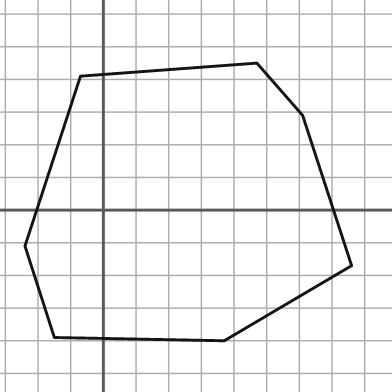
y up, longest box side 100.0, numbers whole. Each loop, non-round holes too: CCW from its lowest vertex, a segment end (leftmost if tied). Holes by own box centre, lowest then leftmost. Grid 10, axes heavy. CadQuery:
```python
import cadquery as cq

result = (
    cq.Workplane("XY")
    .moveTo(37.0, -40.0)
    .lineTo(76.0, -17.0)
    .lineTo(61.0, 29.0)
    .lineTo(47.0, 45.0)
    .lineTo(-7.0, 41.0)
    .lineTo(-24.0, -11.0)
    .lineTo(-15.0, -39.0)
    .close()
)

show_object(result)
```